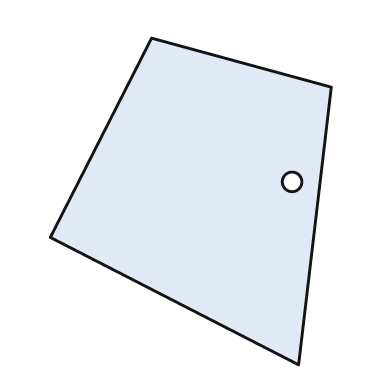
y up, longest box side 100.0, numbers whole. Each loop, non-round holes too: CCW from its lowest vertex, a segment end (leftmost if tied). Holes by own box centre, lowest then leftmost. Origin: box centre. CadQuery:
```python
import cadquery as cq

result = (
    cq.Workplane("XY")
    .moveTo(33.0, -50.0)
    .lineTo(43.0, 35.0)
    .lineTo(-12.0, 50.0)
    .lineTo(-43.0, -11.0)
    .close()
    .moveTo(31.0, 6.0)
    .circle(3.0)
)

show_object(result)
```